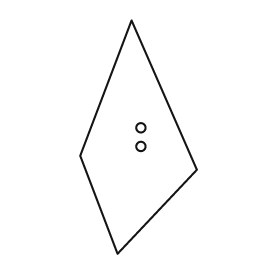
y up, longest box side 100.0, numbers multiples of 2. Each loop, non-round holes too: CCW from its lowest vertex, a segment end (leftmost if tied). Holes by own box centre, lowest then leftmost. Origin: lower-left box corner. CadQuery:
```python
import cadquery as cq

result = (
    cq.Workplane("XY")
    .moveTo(16.0, 0.0)
    .lineTo(50.0, 36.0)
    .lineTo(22.0, 100.0)
    .lineTo(0.0, 42.0)
    .close()
    .moveTo(26.0, 46.0)
    .circle(2.0)
    .moveTo(26.0, 54.0)
    .circle(2.0)
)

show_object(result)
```